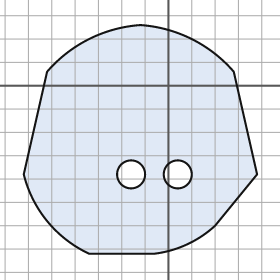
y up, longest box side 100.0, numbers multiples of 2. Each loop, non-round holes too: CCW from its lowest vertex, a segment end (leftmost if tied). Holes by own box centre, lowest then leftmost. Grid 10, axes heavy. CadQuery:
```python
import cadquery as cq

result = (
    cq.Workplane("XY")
    .moveTo(-34.0, -72.0)
    .lineTo(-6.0, -72.0)
    .threePointArc((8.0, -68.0), (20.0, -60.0))
    .lineTo(38.0, -38.0)
    .lineTo(28.0, 6.0)
    .threePointArc((10.0, 20.0), (-12.0, 26.0))
    .threePointArc((-34.0, 20.0), (-52.0, 6.0))
    .lineTo(-62.0, -38.0)
    .threePointArc((-52.0, -58.0), (-34.0, -72.0))
    .close()
    .moveTo(-16.0, -38.0)
    .circle(6.0)
    .moveTo(4.0, -38.0)
    .circle(6.0)
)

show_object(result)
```